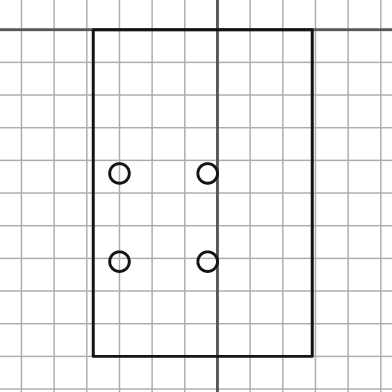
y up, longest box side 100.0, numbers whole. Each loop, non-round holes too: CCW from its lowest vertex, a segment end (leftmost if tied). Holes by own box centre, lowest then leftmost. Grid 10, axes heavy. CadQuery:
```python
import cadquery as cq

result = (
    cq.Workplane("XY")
    .moveTo(-38.0, -100.0)
    .lineTo(29.0, -100.0)
    .lineTo(29.0, 0.0)
    .lineTo(-38.0, 0.0)
    .close()
    .moveTo(-30.0, -71.0)
    .circle(3.0)
    .moveTo(-3.0, -71.0)
    .circle(3.0)
    .moveTo(-30.0, -44.0)
    .circle(3.0)
    .moveTo(-3.0, -44.0)
    .circle(3.0)
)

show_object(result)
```